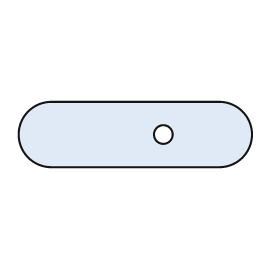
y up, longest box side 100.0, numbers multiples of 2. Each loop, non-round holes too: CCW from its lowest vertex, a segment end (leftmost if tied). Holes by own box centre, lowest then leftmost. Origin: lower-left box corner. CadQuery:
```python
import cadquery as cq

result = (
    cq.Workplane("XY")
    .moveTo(14.0, 0.0)
    .lineTo(86.0, 0.0)
    .threePointArc((100.0, 14.0), (86.0, 28.0))
    .lineTo(14.0, 28.0)
    .threePointArc((0.0, 14.0), (14.0, 0.0))
    .close()
    .moveTo(62.0, 14.0)
    .circle(4.0)
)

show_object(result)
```